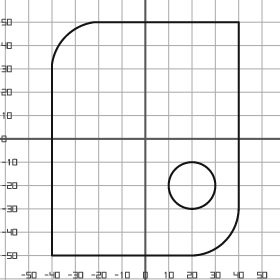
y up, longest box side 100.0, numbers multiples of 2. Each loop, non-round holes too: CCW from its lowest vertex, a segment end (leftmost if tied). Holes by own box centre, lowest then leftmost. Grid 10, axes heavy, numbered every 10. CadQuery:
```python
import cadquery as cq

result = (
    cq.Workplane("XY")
    .moveTo(-40.0, -50.0)
    .lineTo(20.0, -50.0)
    .threePointArc((34.0, -44.0), (40.0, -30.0))
    .lineTo(40.0, 50.0)
    .lineTo(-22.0, 50.0)
    .threePointArc((-34.0, 44.0), (-40.0, 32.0))
    .close()
    .moveTo(20.0, -20.0)
    .circle(10.0)
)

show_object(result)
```